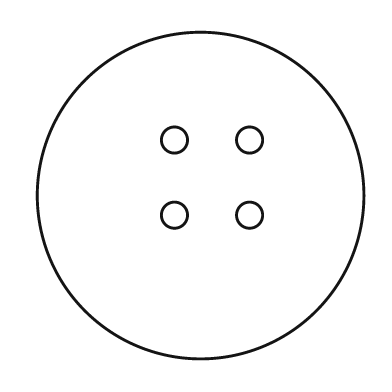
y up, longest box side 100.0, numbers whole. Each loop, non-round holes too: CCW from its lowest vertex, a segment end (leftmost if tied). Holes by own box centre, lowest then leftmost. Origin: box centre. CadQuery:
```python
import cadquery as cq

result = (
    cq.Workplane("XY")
    .moveTo(0.0, 0.0)
    .circle(50.0)
    .moveTo(-8.0, -6.0)
    .circle(4.0)
    .moveTo(15.0, -6.0)
    .circle(4.0)
    .moveTo(-8.0, 17.0)
    .circle(4.0)
    .moveTo(15.0, 17.0)
    .circle(4.0)
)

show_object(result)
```